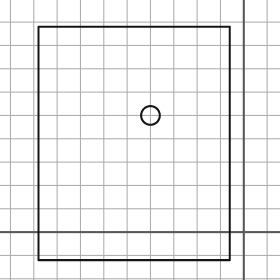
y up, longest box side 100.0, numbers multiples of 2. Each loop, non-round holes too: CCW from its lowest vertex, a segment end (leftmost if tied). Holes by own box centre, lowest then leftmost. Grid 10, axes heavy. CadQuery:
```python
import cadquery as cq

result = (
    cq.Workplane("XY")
    .moveTo(-88.0, -12.0)
    .lineTo(-6.0, -12.0)
    .lineTo(-6.0, 88.0)
    .lineTo(-88.0, 88.0)
    .close()
    .moveTo(-40.0, 50.0)
    .circle(4.0)
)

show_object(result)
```